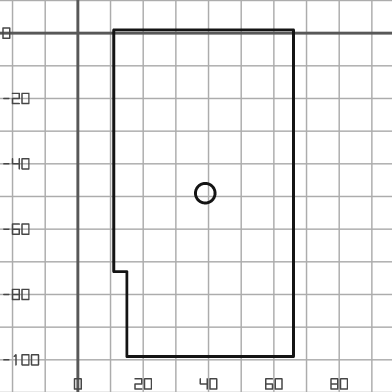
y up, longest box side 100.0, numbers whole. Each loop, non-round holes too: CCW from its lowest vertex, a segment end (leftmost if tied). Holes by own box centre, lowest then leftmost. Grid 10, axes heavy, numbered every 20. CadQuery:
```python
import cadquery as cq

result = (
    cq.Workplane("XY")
    .moveTo(15.0, -99.0)
    .lineTo(66.0, -99.0)
    .lineTo(66.0, 1.0)
    .lineTo(11.0, 1.0)
    .lineTo(11.0, -73.0)
    .lineTo(15.0, -73.0)
    .close()
    .moveTo(39.0, -49.0)
    .circle(3.0)
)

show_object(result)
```